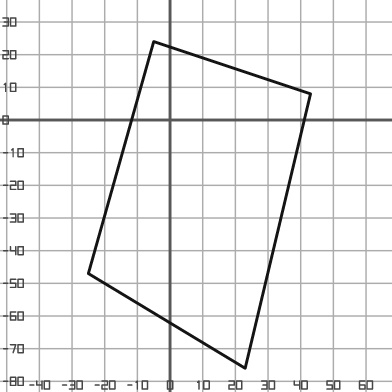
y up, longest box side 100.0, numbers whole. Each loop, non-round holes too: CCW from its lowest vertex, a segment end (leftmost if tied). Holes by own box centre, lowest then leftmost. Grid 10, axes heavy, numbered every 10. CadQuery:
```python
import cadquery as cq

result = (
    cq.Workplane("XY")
    .moveTo(23.0, -76.0)
    .lineTo(43.0, 8.0)
    .lineTo(-5.0, 24.0)
    .lineTo(-25.0, -47.0)
    .close()
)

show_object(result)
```